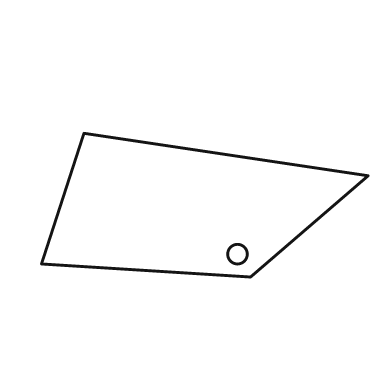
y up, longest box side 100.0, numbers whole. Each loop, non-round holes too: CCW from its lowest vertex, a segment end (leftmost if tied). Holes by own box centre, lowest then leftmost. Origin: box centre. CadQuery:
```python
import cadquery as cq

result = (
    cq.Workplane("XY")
    .moveTo(14.0, -22.0)
    .lineTo(50.0, 9.0)
    .lineTo(-37.0, 22.0)
    .lineTo(-50.0, -18.0)
    .close()
    .moveTo(10.0, -15.0)
    .circle(3.0)
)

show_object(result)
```